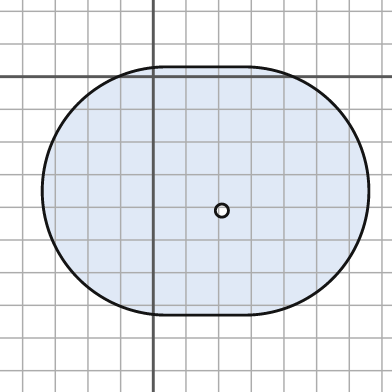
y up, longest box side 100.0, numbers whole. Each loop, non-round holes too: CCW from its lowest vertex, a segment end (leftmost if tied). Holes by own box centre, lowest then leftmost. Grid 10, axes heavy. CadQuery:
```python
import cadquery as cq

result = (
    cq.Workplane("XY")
    .moveTo(4.0, -73.0)
    .lineTo(28.0, -73.0)
    .threePointArc((66.0, -35.0), (28.0, 3.0))
    .lineTo(4.0, 3.0)
    .threePointArc((-34.0, -35.0), (4.0, -73.0))
    .close()
    .moveTo(21.0, -41.0)
    .circle(2.0)
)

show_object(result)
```